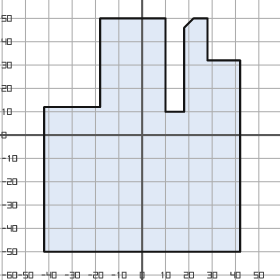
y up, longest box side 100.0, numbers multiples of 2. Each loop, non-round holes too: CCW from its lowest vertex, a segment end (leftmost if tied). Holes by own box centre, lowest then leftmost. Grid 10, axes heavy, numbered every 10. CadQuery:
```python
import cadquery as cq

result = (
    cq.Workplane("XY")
    .moveTo(-42.0, -50.0)
    .lineTo(42.0, -50.0)
    .lineTo(42.0, 32.0)
    .lineTo(28.0, 32.0)
    .lineTo(28.0, 50.0)
    .lineTo(22.0, 50.0)
    .lineTo(18.0, 46.0)
    .lineTo(18.0, 10.0)
    .lineTo(10.0, 10.0)
    .lineTo(10.0, 50.0)
    .lineTo(-18.0, 50.0)
    .lineTo(-18.0, 12.0)
    .lineTo(-42.0, 12.0)
    .close()
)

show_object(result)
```